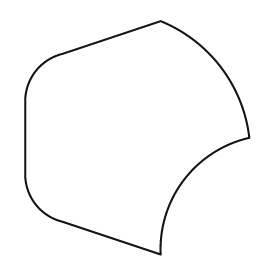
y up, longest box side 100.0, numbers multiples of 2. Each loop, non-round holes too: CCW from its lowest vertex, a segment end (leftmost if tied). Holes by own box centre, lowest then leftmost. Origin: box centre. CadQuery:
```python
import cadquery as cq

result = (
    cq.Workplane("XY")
    .moveTo(10.0, -50.0)
    .threePointArc((20.0, -18.0), (48.0, 0.0))
    .threePointArc((36.0, 30.0), (10.0, 50.0))
    .lineTo(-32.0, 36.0)
    .threePointArc((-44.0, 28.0), (-48.0, 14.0))
    .lineTo(-48.0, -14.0)
    .threePointArc((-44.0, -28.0), (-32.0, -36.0))
    .close()
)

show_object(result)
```